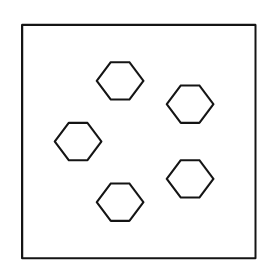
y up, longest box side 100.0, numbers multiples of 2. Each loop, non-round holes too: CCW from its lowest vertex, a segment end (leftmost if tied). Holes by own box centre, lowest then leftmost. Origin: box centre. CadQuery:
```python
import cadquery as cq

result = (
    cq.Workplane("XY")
    .moveTo(-50.0, -50.0)
    .lineTo(50.0, -50.0)
    .lineTo(50.0, 50.0)
    .lineTo(-50.0, 50.0)
    .close()
    .moveTo(-12.0, -34.0)
    .lineTo(-4.0, -34.0)
    .lineTo(2.0, -26.0)
    .lineTo(-4.0, -18.0)
    .lineTo(-12.0, -18.0)
    .lineTo(-18.0, -26.0)
    .close()
    .moveTo(18.0, -24.0)
    .lineTo(26.0, -24.0)
    .lineTo(32.0, -16.0)
    .lineTo(26.0, -8.0)
    .lineTo(18.0, -8.0)
    .lineTo(12.0, -16.0)
    .close()
    .moveTo(-30.0, -8.0)
    .lineTo(-22.0, -8.0)
    .lineTo(-16.0, 0.0)
    .lineTo(-22.0, 8.0)
    .lineTo(-30.0, 8.0)
    .lineTo(-36.0, 0.0)
    .close()
    .moveTo(18.0, 8.0)
    .lineTo(26.0, 8.0)
    .lineTo(32.0, 16.0)
    .lineTo(26.0, 24.0)
    .lineTo(18.0, 24.0)
    .lineTo(12.0, 16.0)
    .close()
    .moveTo(-12.0, 18.0)
    .lineTo(-4.0, 18.0)
    .lineTo(2.0, 26.0)
    .lineTo(-4.0, 34.0)
    .lineTo(-12.0, 34.0)
    .lineTo(-18.0, 26.0)
    .close()
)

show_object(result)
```